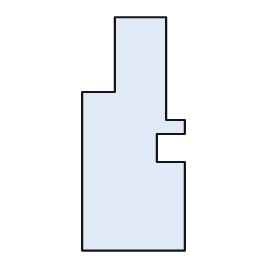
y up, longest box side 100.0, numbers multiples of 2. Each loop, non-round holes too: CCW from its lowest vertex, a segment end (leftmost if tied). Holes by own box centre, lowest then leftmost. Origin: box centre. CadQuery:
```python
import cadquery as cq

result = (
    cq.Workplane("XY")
    .moveTo(-22.0, -50.0)
    .lineTo(22.0, -50.0)
    .lineTo(22.0, -12.0)
    .lineTo(10.0, -12.0)
    .lineTo(10.0, 0.0)
    .lineTo(22.0, 0.0)
    .lineTo(22.0, 6.0)
    .lineTo(14.0, 6.0)
    .lineTo(14.0, 50.0)
    .lineTo(-8.0, 50.0)
    .lineTo(-8.0, 18.0)
    .lineTo(-22.0, 18.0)
    .close()
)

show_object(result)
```